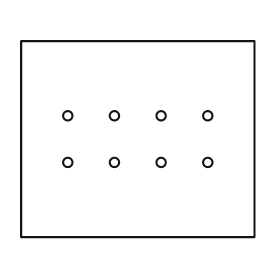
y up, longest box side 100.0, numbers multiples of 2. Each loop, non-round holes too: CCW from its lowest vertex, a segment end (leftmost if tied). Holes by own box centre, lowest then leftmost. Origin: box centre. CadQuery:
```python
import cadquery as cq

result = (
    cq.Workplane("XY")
    .moveTo(-50.0, -42.0)
    .lineTo(50.0, -42.0)
    .lineTo(50.0, 42.0)
    .lineTo(-50.0, 42.0)
    .close()
    .moveTo(-30.0, -10.0)
    .circle(2.0)
    .moveTo(-10.0, -10.0)
    .circle(2.0)
    .moveTo(10.0, -10.0)
    .circle(2.0)
    .moveTo(30.0, -10.0)
    .circle(2.0)
    .moveTo(-30.0, 10.0)
    .circle(2.0)
    .moveTo(-10.0, 10.0)
    .circle(2.0)
    .moveTo(10.0, 10.0)
    .circle(2.0)
    .moveTo(30.0, 10.0)
    .circle(2.0)
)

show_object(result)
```